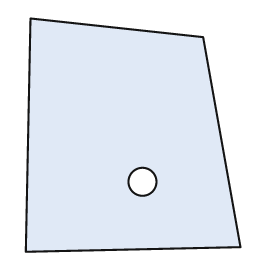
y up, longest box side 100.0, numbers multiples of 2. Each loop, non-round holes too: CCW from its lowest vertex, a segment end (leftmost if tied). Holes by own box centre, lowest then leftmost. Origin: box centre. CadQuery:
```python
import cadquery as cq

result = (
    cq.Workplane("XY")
    .moveTo(-46.0, -50.0)
    .lineTo(46.0, -48.0)
    .lineTo(30.0, 42.0)
    .lineTo(-44.0, 50.0)
    .close()
    .moveTo(4.0, -20.0)
    .circle(6.0)
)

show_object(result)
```